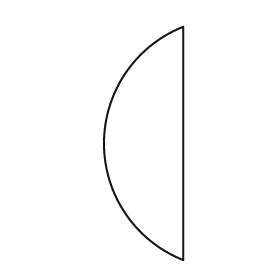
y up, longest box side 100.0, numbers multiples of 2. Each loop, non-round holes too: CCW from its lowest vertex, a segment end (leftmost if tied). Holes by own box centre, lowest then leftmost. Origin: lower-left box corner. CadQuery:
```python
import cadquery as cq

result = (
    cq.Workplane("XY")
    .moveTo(34.0, 0.0)
    .lineTo(34.0, 100.0)
    .threePointArc((0.0, 50.0), (34.0, 0.0))
    .close()
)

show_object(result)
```